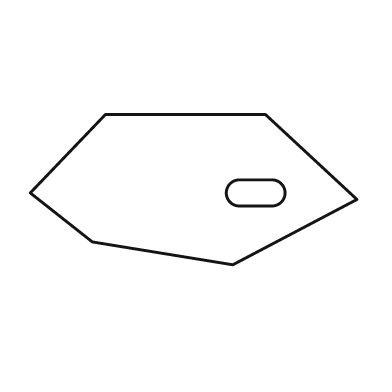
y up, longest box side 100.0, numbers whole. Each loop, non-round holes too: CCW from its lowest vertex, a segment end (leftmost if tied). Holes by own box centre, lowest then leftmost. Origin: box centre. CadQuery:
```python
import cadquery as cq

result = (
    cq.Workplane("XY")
    .moveTo(12.0, -23.0)
    .lineTo(50.0, -3.0)
    .lineTo(22.0, 23.0)
    .lineTo(-27.0, 23.0)
    .lineTo(-50.0, -1.0)
    .lineTo(-31.0, -16.0)
    .close()
    .moveTo(14.0, -5.0)
    .lineTo(24.0, -5.0)
    .threePointArc((28.0, -1.0), (24.0, 3.0))
    .lineTo(14.0, 3.0)
    .threePointArc((10.0, -1.0), (14.0, -5.0))
    .close()
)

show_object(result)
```